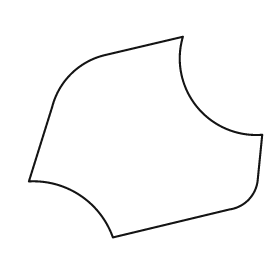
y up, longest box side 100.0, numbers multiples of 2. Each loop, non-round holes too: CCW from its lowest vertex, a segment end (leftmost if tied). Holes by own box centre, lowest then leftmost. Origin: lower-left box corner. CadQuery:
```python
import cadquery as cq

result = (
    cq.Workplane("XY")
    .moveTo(36.0, 0.0)
    .lineTo(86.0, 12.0)
    .threePointArc((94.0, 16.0), (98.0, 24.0))
    .lineTo(100.0, 44.0)
    .threePointArc((72.0, 56.0), (66.0, 86.0))
    .lineTo(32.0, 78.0)
    .threePointArc((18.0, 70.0), (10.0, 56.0))
    .lineTo(0.0, 24.0)
    .threePointArc((22.0, 18.0), (36.0, 0.0))
    .close()
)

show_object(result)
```